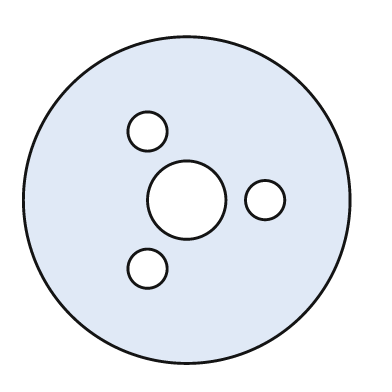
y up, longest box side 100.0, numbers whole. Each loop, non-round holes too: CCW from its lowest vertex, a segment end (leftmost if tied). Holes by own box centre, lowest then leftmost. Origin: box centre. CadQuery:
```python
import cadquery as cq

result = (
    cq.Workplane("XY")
    .moveTo(0.0, 0.0)
    .circle(50.0)
    .moveTo(-12.0, -21.0)
    .circle(6.0)
    .moveTo(0.0, 0.0)
    .circle(12.0)
    .moveTo(24.0, 0.0)
    .circle(6.0)
    .moveTo(-12.0, 21.0)
    .circle(6.0)
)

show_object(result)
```